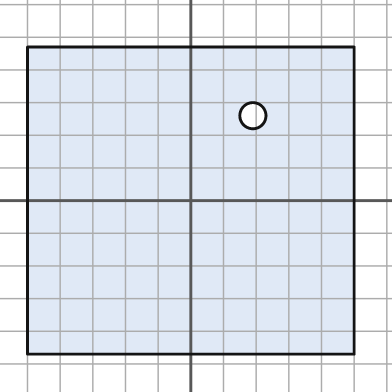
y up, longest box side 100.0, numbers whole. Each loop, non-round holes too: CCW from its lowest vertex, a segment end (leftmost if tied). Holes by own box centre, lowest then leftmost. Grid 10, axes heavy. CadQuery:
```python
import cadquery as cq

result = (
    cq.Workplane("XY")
    .moveTo(-50.0, -47.0)
    .lineTo(50.0, -47.0)
    .lineTo(50.0, 47.0)
    .lineTo(-50.0, 47.0)
    .close()
    .moveTo(19.0, 26.0)
    .circle(4.0)
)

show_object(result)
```